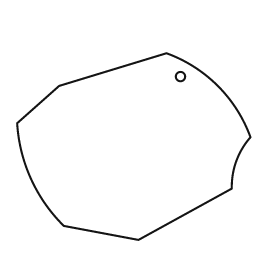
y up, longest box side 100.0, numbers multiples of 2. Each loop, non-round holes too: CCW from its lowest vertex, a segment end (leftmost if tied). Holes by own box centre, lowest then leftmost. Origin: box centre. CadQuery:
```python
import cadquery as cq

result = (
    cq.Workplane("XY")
    .moveTo(2.0, -40.0)
    .lineTo(42.0, -18.0)
    .threePointArc((44.0, -6.0), (50.0, 4.0))
    .threePointArc((36.0, 26.0), (14.0, 40.0))
    .lineTo(-32.0, 26.0)
    .lineTo(-50.0, 10.0)
    .threePointArc((-44.0, -14.0), (-30.0, -34.0))
    .close()
    .moveTo(20.0, 30.0)
    .circle(2.0)
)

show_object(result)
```